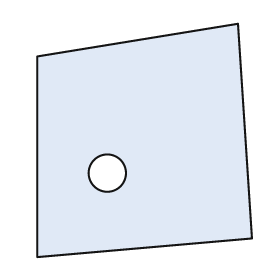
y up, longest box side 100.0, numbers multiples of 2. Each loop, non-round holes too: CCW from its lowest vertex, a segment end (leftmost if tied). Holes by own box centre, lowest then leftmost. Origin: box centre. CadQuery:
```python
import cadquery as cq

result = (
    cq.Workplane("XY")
    .moveTo(-46.0, -50.0)
    .lineTo(46.0, -42.0)
    .lineTo(40.0, 50.0)
    .lineTo(-46.0, 36.0)
    .close()
    .moveTo(-16.0, -14.0)
    .circle(8.0)
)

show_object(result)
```